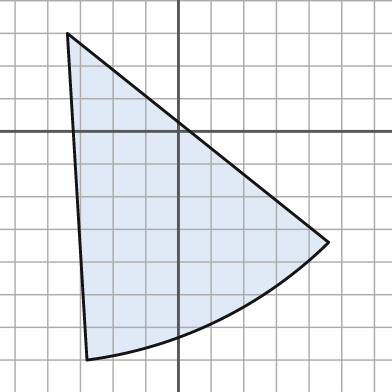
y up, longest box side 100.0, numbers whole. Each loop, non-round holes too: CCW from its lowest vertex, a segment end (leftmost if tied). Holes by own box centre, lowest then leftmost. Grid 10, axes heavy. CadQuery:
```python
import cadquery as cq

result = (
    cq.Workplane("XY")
    .moveTo(-28.0, -70.0)
    .threePointArc((12.0, -58.0), (46.0, -34.0))
    .lineTo(-34.0, 30.0)
    .close()
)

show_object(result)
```